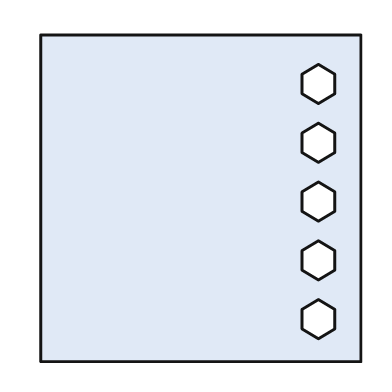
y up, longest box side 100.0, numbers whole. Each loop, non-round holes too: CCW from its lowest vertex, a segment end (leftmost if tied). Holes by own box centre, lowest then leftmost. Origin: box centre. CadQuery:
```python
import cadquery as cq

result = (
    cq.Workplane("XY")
    .moveTo(-49.0, -50.0)
    .lineTo(49.0, -50.0)
    .lineTo(49.0, 50.0)
    .lineTo(-49.0, 50.0)
    .close()
    .moveTo(36.0, -43.0)
    .lineTo(41.0, -40.0)
    .lineTo(41.0, -34.0)
    .lineTo(36.0, -31.0)
    .lineTo(31.0, -34.0)
    .lineTo(31.0, -40.0)
    .close()
    .moveTo(36.0, -25.0)
    .lineTo(41.0, -22.0)
    .lineTo(41.0, -16.0)
    .lineTo(36.0, -13.0)
    .lineTo(31.0, -16.0)
    .lineTo(31.0, -22.0)
    .close()
    .moveTo(36.0, -7.0)
    .lineTo(41.0, -4.0)
    .lineTo(41.0, 2.0)
    .lineTo(36.0, 5.0)
    .lineTo(31.0, 2.0)
    .lineTo(31.0, -4.0)
    .close()
    .moveTo(36.0, 11.0)
    .lineTo(41.0, 14.0)
    .lineTo(41.0, 20.0)
    .lineTo(36.0, 23.0)
    .lineTo(31.0, 20.0)
    .lineTo(31.0, 14.0)
    .close()
    .moveTo(36.0, 29.0)
    .lineTo(41.0, 32.0)
    .lineTo(41.0, 38.0)
    .lineTo(36.0, 41.0)
    .lineTo(31.0, 38.0)
    .lineTo(31.0, 32.0)
    .close()
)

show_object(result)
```